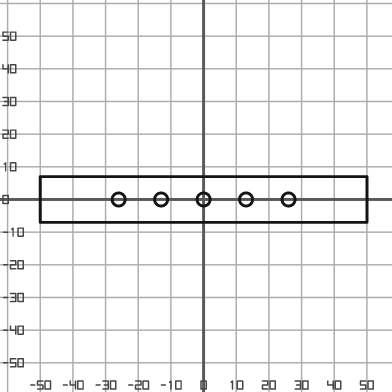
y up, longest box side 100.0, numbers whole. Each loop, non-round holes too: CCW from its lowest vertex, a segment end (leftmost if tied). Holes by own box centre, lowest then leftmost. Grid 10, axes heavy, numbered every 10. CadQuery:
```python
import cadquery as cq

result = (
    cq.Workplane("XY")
    .moveTo(-50.0, -7.0)
    .lineTo(50.0, -7.0)
    .lineTo(50.0, 7.0)
    .lineTo(-50.0, 7.0)
    .close()
    .moveTo(-26.0, 0.0)
    .circle(2.0)
    .moveTo(-13.0, 0.0)
    .circle(2.0)
    .moveTo(0.0, 0.0)
    .circle(2.0)
    .moveTo(13.0, 0.0)
    .circle(2.0)
    .moveTo(26.0, 0.0)
    .circle(2.0)
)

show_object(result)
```